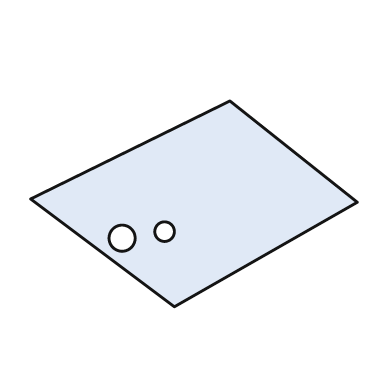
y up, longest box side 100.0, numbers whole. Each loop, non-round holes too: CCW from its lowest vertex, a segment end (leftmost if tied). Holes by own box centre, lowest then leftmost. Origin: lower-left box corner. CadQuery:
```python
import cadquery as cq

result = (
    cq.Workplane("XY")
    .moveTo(44.0, 0.0)
    .lineTo(100.0, 32.0)
    .lineTo(61.0, 63.0)
    .lineTo(0.0, 33.0)
    .close()
    .moveTo(28.0, 21.0)
    .circle(4.0)
    .moveTo(41.0, 23.0)
    .circle(3.0)
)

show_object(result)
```